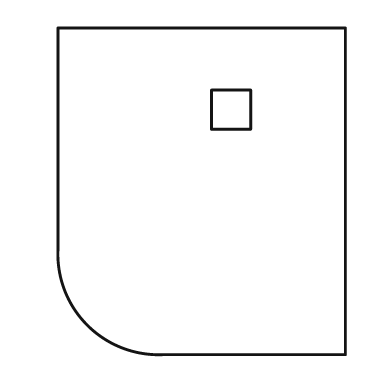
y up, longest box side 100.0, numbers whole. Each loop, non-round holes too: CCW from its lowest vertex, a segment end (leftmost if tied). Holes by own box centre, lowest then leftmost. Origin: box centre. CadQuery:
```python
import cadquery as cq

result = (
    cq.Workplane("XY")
    .moveTo(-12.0, -50.0)
    .lineTo(44.0, -50.0)
    .lineTo(44.0, 50.0)
    .lineTo(-44.0, 50.0)
    .lineTo(-44.0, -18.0)
    .threePointArc((-35.0, -41.0), (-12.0, -50.0))
    .close()
    .moveTo(3.0, 19.0)
    .lineTo(15.0, 19.0)
    .lineTo(15.0, 31.0)
    .lineTo(3.0, 31.0)
    .close()
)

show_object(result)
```